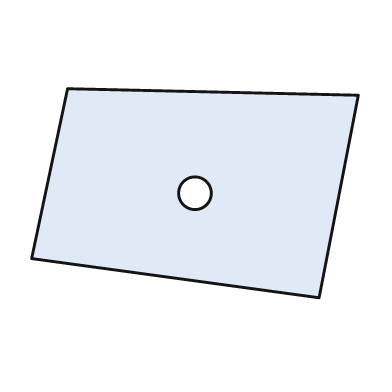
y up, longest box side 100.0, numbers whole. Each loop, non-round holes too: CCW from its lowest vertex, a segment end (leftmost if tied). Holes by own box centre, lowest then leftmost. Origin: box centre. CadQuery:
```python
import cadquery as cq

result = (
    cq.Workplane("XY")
    .moveTo(38.0, -32.0)
    .lineTo(50.0, 30.0)
    .lineTo(-39.0, 32.0)
    .lineTo(-50.0, -20.0)
    .close()
    .moveTo(0.0, 0.0)
    .circle(5.0)
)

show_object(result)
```